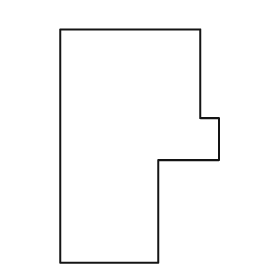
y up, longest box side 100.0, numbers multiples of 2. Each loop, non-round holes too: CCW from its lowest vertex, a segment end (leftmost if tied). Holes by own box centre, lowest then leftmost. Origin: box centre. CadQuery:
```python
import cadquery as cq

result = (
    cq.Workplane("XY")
    .moveTo(-34.0, -50.0)
    .lineTo(8.0, -50.0)
    .lineTo(8.0, -6.0)
    .lineTo(34.0, -6.0)
    .lineTo(34.0, 12.0)
    .lineTo(26.0, 12.0)
    .lineTo(26.0, 50.0)
    .lineTo(-34.0, 50.0)
    .close()
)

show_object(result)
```